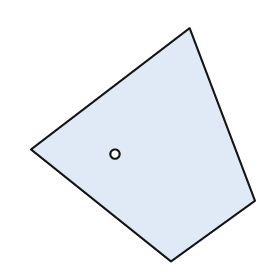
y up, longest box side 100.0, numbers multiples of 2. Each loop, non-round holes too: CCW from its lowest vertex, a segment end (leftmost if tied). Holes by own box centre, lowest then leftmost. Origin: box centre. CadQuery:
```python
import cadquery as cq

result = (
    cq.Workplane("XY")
    .moveTo(12.0, -50.0)
    .lineTo(48.0, -24.0)
    .lineTo(20.0, 50.0)
    .lineTo(-48.0, -2.0)
    .close()
    .moveTo(-12.0, -4.0)
    .circle(2.0)
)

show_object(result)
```